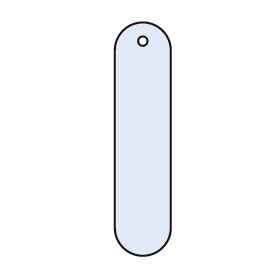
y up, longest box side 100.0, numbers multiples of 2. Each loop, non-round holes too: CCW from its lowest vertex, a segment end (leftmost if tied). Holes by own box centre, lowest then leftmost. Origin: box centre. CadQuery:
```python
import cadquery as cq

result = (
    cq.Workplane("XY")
    .moveTo(-12.0, -38.0)
    .threePointArc((0.0, -50.0), (12.0, -38.0))
    .lineTo(12.0, 38.0)
    .threePointArc((0.0, 50.0), (-12.0, 38.0))
    .close()
    .moveTo(0.0, 42.0)
    .circle(2.0)
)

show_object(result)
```